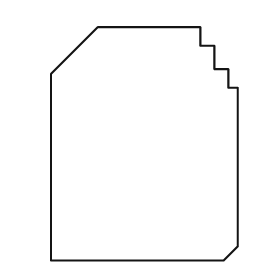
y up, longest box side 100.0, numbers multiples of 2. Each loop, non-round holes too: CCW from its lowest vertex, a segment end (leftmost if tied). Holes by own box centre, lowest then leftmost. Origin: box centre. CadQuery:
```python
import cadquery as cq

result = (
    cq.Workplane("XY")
    .moveTo(-40.0, -50.0)
    .lineTo(34.0, -50.0)
    .lineTo(40.0, -44.0)
    .lineTo(40.0, 24.0)
    .lineTo(36.0, 24.0)
    .lineTo(36.0, 32.0)
    .lineTo(30.0, 32.0)
    .lineTo(30.0, 42.0)
    .lineTo(24.0, 42.0)
    .lineTo(24.0, 50.0)
    .lineTo(-20.0, 50.0)
    .lineTo(-40.0, 30.0)
    .close()
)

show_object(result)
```